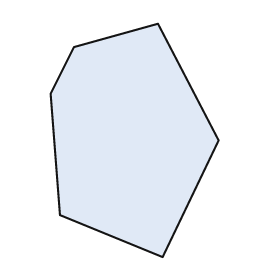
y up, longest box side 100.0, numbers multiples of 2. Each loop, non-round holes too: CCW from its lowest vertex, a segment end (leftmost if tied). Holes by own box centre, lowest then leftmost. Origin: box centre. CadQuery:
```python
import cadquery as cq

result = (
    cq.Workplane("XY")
    .moveTo(12.0, -50.0)
    .lineTo(36.0, 0.0)
    .lineTo(10.0, 50.0)
    .lineTo(-26.0, 40.0)
    .lineTo(-36.0, 20.0)
    .lineTo(-32.0, -32.0)
    .close()
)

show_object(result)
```